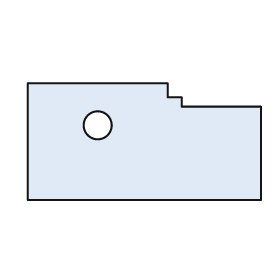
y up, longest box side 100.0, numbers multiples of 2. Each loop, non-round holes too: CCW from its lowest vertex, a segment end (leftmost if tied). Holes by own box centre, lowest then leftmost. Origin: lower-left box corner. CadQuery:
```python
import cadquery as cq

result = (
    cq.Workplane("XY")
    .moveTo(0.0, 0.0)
    .lineTo(100.0, 0.0)
    .lineTo(100.0, 40.0)
    .lineTo(66.0, 40.0)
    .lineTo(66.0, 44.0)
    .lineTo(60.0, 44.0)
    .lineTo(60.0, 50.0)
    .lineTo(0.0, 50.0)
    .close()
    .moveTo(30.0, 32.0)
    .circle(6.0)
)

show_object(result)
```